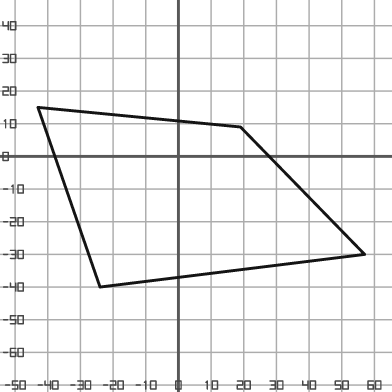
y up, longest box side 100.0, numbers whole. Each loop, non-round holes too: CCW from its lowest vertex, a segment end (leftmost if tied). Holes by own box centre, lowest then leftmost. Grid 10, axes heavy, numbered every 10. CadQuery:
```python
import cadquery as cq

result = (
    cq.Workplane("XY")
    .moveTo(-24.0, -40.0)
    .lineTo(57.0, -30.0)
    .lineTo(19.0, 9.0)
    .lineTo(-43.0, 15.0)
    .close()
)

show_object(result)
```